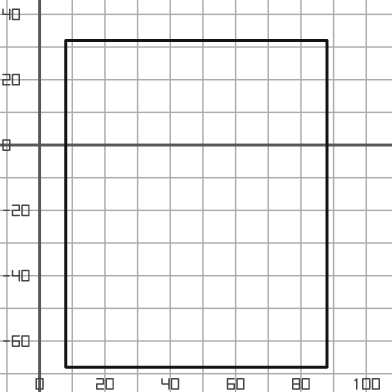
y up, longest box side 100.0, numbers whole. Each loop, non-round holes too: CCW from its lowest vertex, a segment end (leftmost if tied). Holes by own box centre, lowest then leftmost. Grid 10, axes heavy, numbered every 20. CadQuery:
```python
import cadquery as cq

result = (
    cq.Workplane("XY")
    .moveTo(8.0, -68.0)
    .lineTo(88.0, -68.0)
    .lineTo(88.0, 32.0)
    .lineTo(8.0, 32.0)
    .close()
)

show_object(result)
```